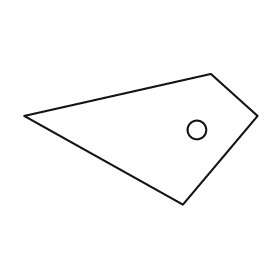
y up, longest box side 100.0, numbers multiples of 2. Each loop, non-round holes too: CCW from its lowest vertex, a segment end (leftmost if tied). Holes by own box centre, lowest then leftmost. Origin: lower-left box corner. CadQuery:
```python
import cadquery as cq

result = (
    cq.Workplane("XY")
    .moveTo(68.0, 0.0)
    .lineTo(100.0, 38.0)
    .lineTo(80.0, 56.0)
    .lineTo(0.0, 38.0)
    .close()
    .moveTo(74.0, 32.0)
    .circle(4.0)
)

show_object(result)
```